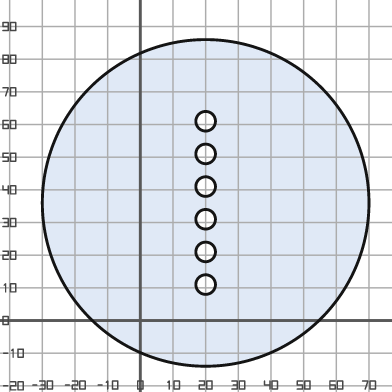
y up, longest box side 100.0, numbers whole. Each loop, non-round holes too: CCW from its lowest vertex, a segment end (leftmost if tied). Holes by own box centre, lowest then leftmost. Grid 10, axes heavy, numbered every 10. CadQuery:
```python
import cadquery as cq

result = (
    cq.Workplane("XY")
    .moveTo(20.0, 36.0)
    .circle(50.0)
    .moveTo(20.0, 11.0)
    .circle(3.0)
    .moveTo(20.0, 21.0)
    .circle(3.0)
    .moveTo(20.0, 31.0)
    .circle(3.0)
    .moveTo(20.0, 41.0)
    .circle(3.0)
    .moveTo(20.0, 51.0)
    .circle(3.0)
    .moveTo(20.0, 61.0)
    .circle(3.0)
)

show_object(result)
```